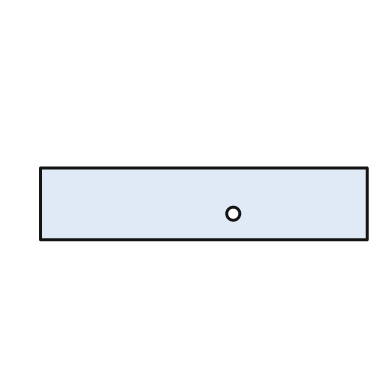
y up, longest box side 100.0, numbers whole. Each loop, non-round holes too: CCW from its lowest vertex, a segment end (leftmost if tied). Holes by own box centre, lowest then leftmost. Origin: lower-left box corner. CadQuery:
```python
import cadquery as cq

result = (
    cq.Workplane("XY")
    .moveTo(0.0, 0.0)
    .lineTo(100.0, 0.0)
    .lineTo(100.0, 22.0)
    .lineTo(0.0, 22.0)
    .close()
    .moveTo(59.0, 8.0)
    .circle(2.0)
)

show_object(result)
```